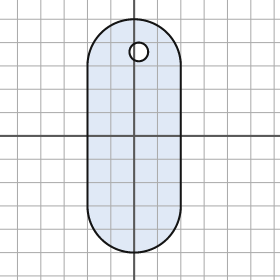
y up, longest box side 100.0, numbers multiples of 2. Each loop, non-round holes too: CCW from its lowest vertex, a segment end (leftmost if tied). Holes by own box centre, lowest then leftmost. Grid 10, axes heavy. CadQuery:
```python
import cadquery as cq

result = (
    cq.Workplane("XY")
    .moveTo(-20.0, -30.0)
    .threePointArc((0.0, -50.0), (20.0, -30.0))
    .lineTo(20.0, 30.0)
    .threePointArc((0.0, 50.0), (-20.0, 30.0))
    .close()
    .moveTo(2.0, 36.0)
    .circle(4.0)
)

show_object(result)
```